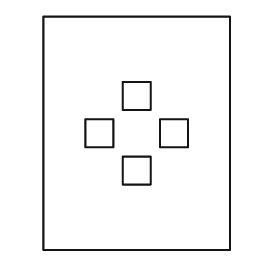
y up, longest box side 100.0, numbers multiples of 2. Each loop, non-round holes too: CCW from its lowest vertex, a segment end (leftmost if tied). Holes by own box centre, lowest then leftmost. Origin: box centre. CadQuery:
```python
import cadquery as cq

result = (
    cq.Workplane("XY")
    .moveTo(-40.0, -50.0)
    .lineTo(40.0, -50.0)
    .lineTo(40.0, 50.0)
    .lineTo(-40.0, 50.0)
    .close()
    .moveTo(-6.0, -22.0)
    .lineTo(6.0, -22.0)
    .lineTo(6.0, -10.0)
    .lineTo(-6.0, -10.0)
    .close()
    .moveTo(-22.0, -6.0)
    .lineTo(-10.0, -6.0)
    .lineTo(-10.0, 6.0)
    .lineTo(-22.0, 6.0)
    .close()
    .moveTo(10.0, -6.0)
    .lineTo(22.0, -6.0)
    .lineTo(22.0, 6.0)
    .lineTo(10.0, 6.0)
    .close()
    .moveTo(-6.0, 10.0)
    .lineTo(6.0, 10.0)
    .lineTo(6.0, 22.0)
    .lineTo(-6.0, 22.0)
    .close()
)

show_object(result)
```